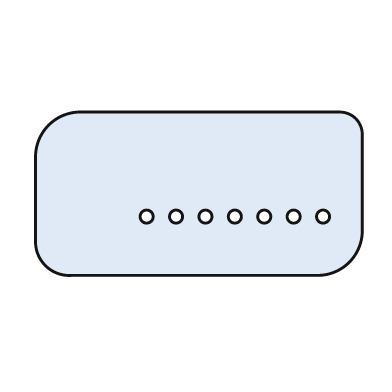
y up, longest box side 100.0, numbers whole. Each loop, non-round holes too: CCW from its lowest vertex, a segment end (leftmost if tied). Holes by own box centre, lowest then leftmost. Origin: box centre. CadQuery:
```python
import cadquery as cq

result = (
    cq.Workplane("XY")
    .moveTo(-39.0, -25.0)
    .lineTo(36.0, -25.0)
    .threePointArc((46.0, -21.0), (50.0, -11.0))
    .lineTo(50.0, 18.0)
    .threePointArc((48.0, 23.0), (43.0, 25.0))
    .lineTo(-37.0, 25.0)
    .threePointArc((-46.0, 21.0), (-50.0, 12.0))
    .lineTo(-50.0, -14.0)
    .threePointArc((-47.0, -22.0), (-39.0, -25.0))
    .close()
    .moveTo(-16.0, -7.0)
    .circle(2.0)
    .moveTo(-7.0, -7.0)
    .circle(2.0)
    .moveTo(2.0, -7.0)
    .circle(2.0)
    .moveTo(11.0, -7.0)
    .circle(2.0)
    .moveTo(20.0, -7.0)
    .circle(2.0)
    .moveTo(29.0, -7.0)
    .circle(2.0)
    .moveTo(38.0, -7.0)
    .circle(2.0)
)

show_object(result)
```